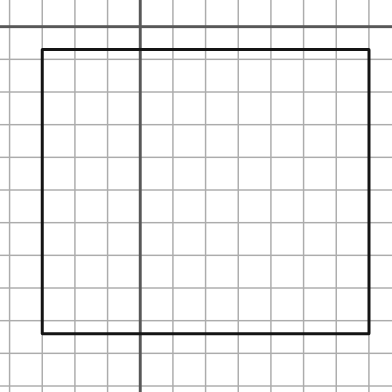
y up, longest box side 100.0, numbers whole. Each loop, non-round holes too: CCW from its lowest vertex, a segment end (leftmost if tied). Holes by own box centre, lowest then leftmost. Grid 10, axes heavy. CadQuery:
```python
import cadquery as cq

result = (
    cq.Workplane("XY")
    .moveTo(-30.0, -94.0)
    .lineTo(70.0, -94.0)
    .lineTo(70.0, -7.0)
    .lineTo(-30.0, -7.0)
    .close()
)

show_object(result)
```